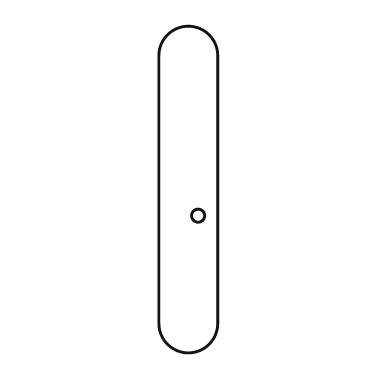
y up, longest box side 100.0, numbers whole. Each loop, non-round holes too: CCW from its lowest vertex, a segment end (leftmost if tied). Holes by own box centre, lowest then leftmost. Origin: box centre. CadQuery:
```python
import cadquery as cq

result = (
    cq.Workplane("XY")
    .moveTo(-9.0, -41.0)
    .threePointArc((0.0, -50.0), (9.0, -41.0))
    .lineTo(9.0, 41.0)
    .threePointArc((0.0, 50.0), (-9.0, 41.0))
    .close()
    .moveTo(3.0, -8.0)
    .circle(2.0)
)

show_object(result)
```